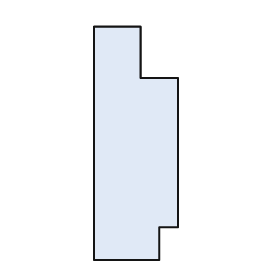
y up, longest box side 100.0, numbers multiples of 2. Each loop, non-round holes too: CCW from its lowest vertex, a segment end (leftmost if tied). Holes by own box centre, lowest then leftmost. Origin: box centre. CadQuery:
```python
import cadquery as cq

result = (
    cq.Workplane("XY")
    .moveTo(-18.0, -50.0)
    .lineTo(10.0, -50.0)
    .lineTo(10.0, -36.0)
    .lineTo(18.0, -36.0)
    .lineTo(18.0, 28.0)
    .lineTo(2.0, 28.0)
    .lineTo(2.0, 50.0)
    .lineTo(-18.0, 50.0)
    .close()
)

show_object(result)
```